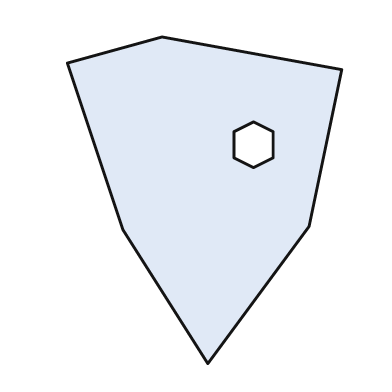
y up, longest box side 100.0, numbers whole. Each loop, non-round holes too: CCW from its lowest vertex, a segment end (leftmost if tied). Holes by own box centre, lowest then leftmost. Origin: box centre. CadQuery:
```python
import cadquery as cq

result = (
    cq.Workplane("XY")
    .moveTo(1.0, -50.0)
    .lineTo(32.0, -8.0)
    .lineTo(42.0, 40.0)
    .lineTo(-13.0, 50.0)
    .lineTo(-42.0, 42.0)
    .lineTo(-25.0, -9.0)
    .close()
    .moveTo(15.0, 10.0)
    .lineTo(21.0, 13.0)
    .lineTo(21.0, 21.0)
    .lineTo(15.0, 24.0)
    .lineTo(9.0, 21.0)
    .lineTo(9.0, 13.0)
    .close()
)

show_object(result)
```